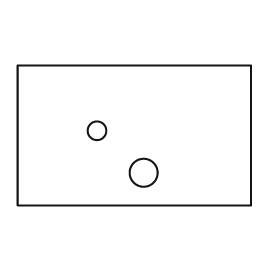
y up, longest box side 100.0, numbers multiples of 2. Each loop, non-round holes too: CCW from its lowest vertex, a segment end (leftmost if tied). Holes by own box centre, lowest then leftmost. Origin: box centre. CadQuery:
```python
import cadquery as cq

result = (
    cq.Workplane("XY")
    .moveTo(-50.0, -30.0)
    .lineTo(50.0, -30.0)
    .lineTo(50.0, 30.0)
    .lineTo(-50.0, 30.0)
    .close()
    .moveTo(4.0, -16.0)
    .circle(6.0)
    .moveTo(-16.0, 2.0)
    .circle(4.0)
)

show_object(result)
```